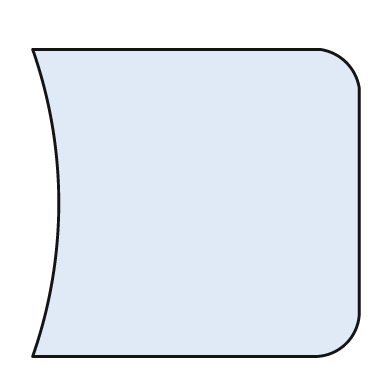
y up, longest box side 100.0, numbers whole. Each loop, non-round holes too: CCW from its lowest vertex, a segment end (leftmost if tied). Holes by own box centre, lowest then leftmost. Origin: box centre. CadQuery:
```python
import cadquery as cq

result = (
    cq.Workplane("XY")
    .moveTo(-50.0, -47.0)
    .lineTo(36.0, -47.0)
    .threePointArc((46.0, -43.0), (50.0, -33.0))
    .lineTo(50.0, 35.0)
    .threePointArc((46.0, 43.0), (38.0, 47.0))
    .lineTo(-50.0, 47.0)
    .threePointArc((-42.0, 0.0), (-50.0, -47.0))
    .close()
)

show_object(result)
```